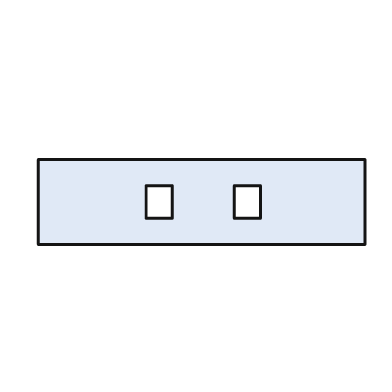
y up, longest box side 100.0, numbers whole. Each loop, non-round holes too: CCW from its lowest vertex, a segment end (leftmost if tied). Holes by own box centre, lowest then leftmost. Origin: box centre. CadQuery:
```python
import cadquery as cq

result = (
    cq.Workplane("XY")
    .moveTo(-50.0, -13.0)
    .lineTo(50.0, -13.0)
    .lineTo(50.0, 13.0)
    .lineTo(-50.0, 13.0)
    .close()
    .moveTo(-17.0, -5.0)
    .lineTo(-9.0, -5.0)
    .lineTo(-9.0, 5.0)
    .lineTo(-17.0, 5.0)
    .close()
    .moveTo(10.0, -5.0)
    .lineTo(18.0, -5.0)
    .lineTo(18.0, 5.0)
    .lineTo(10.0, 5.0)
    .close()
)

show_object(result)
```